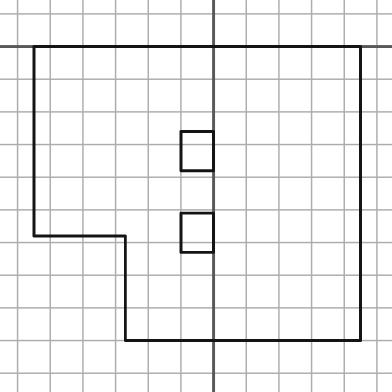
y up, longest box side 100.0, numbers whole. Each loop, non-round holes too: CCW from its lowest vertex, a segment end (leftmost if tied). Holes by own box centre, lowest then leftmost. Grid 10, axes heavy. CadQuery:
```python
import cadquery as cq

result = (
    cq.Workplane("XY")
    .moveTo(-27.0, -90.0)
    .lineTo(45.0, -90.0)
    .lineTo(45.0, 0.0)
    .lineTo(-55.0, 0.0)
    .lineTo(-55.0, -58.0)
    .lineTo(-27.0, -58.0)
    .close()
    .moveTo(-10.0, -63.0)
    .lineTo(0.0, -63.0)
    .lineTo(0.0, -51.0)
    .lineTo(-10.0, -51.0)
    .close()
    .moveTo(-10.0, -38.0)
    .lineTo(0.0, -38.0)
    .lineTo(0.0, -26.0)
    .lineTo(-10.0, -26.0)
    .close()
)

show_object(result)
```